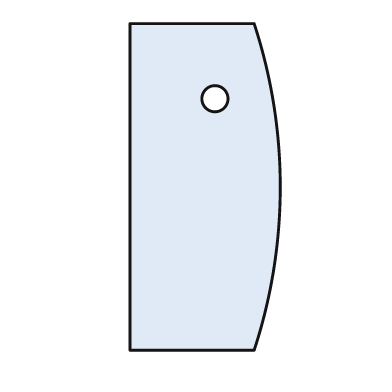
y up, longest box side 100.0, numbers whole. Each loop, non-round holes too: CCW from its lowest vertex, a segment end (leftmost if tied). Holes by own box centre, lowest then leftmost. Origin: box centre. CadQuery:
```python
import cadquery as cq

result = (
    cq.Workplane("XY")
    .moveTo(-23.0, -50.0)
    .lineTo(15.0, -50.0)
    .threePointArc((23.0, 0.0), (15.0, 50.0))
    .lineTo(-23.0, 50.0)
    .close()
    .moveTo(3.0, 27.0)
    .circle(4.0)
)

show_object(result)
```